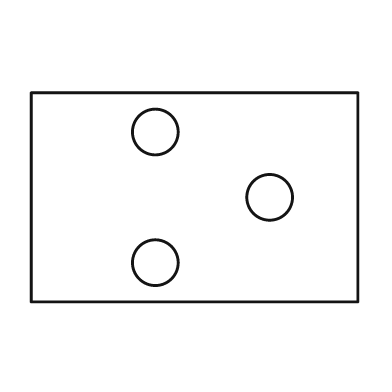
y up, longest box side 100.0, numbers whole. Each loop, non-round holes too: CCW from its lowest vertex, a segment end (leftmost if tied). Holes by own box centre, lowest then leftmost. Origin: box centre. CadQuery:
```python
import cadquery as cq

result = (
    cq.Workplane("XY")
    .moveTo(-50.0, -32.0)
    .lineTo(50.0, -32.0)
    .lineTo(50.0, 32.0)
    .lineTo(-50.0, 32.0)
    .close()
    .moveTo(-12.0, -20.0)
    .circle(7.0)
    .moveTo(23.0, 0.0)
    .circle(7.0)
    .moveTo(-12.0, 20.0)
    .circle(7.0)
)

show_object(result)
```